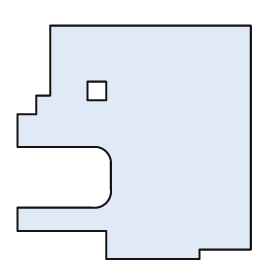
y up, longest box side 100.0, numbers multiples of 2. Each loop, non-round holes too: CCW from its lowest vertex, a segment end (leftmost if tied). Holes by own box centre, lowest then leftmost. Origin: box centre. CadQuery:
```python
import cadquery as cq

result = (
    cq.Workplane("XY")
    .moveTo(-12.0, -50.0)
    .lineTo(28.0, -50.0)
    .lineTo(28.0, -46.0)
    .lineTo(50.0, -46.0)
    .lineTo(50.0, 50.0)
    .lineTo(-36.0, 50.0)
    .lineTo(-36.0, 20.0)
    .lineTo(-42.0, 20.0)
    .lineTo(-42.0, 12.0)
    .lineTo(-50.0, 12.0)
    .lineTo(-50.0, -2.0)
    .lineTo(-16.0, -2.0)
    .threePointArc((-12.0, -4.0), (-10.0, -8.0))
    .lineTo(-10.0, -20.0)
    .threePointArc((-12.0, -26.0), (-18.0, -28.0))
    .lineTo(-50.0, -28.0)
    .lineTo(-50.0, -38.0)
    .lineTo(-12.0, -38.0)
    .close()
    .moveTo(-20.0, 18.0)
    .lineTo(-12.0, 18.0)
    .lineTo(-12.0, 26.0)
    .lineTo(-20.0, 26.0)
    .close()
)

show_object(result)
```